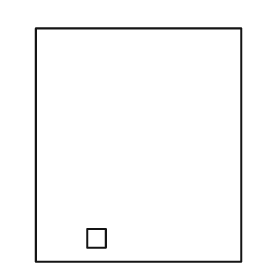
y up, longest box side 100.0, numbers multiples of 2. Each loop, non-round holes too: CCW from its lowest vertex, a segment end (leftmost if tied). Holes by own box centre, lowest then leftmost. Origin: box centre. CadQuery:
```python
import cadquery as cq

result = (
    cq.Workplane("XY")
    .moveTo(-44.0, -50.0)
    .lineTo(44.0, -50.0)
    .lineTo(44.0, 50.0)
    .lineTo(-44.0, 50.0)
    .close()
    .moveTo(-22.0, -44.0)
    .lineTo(-14.0, -44.0)
    .lineTo(-14.0, -36.0)
    .lineTo(-22.0, -36.0)
    .close()
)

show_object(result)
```